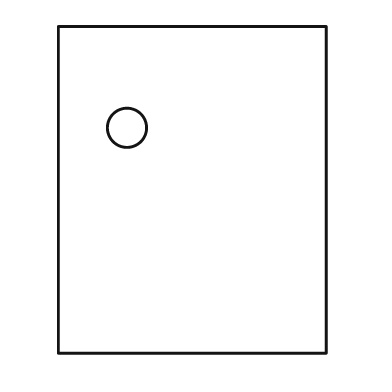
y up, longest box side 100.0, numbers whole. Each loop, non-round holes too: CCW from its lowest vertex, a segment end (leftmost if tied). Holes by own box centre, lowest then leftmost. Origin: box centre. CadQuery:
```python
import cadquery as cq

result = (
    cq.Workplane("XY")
    .moveTo(-41.0, -50.0)
    .lineTo(41.0, -50.0)
    .lineTo(41.0, 50.0)
    .lineTo(-41.0, 50.0)
    .close()
    .moveTo(-20.0, 19.0)
    .circle(6.0)
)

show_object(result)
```